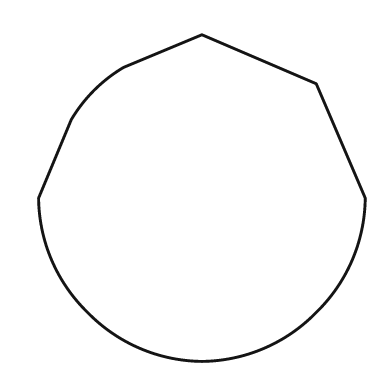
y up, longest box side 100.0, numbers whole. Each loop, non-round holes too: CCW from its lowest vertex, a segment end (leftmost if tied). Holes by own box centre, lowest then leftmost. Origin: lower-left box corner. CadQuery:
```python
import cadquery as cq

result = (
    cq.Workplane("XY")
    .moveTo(50.0, 0.0)
    .threePointArc((69.0, 4.0), (85.0, 15.0))
    .threePointArc((96.0, 31.0), (100.0, 50.0))
    .lineTo(85.0, 85.0)
    .lineTo(50.0, 100.0)
    .lineTo(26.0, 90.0)
    .threePointArc((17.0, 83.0), (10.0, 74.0))
    .lineTo(0.0, 50.0)
    .threePointArc((4.0, 31.0), (15.0, 15.0))
    .threePointArc((31.0, 4.0), (50.0, 0.0))
    .close()
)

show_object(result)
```